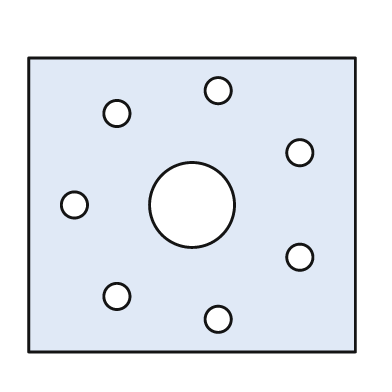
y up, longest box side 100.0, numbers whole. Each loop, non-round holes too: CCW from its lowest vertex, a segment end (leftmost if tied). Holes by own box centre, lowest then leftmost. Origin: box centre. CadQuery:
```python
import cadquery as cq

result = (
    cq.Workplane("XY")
    .moveTo(-50.0, -45.0)
    .lineTo(50.0, -45.0)
    .lineTo(50.0, 45.0)
    .lineTo(-50.0, 45.0)
    .close()
    .moveTo(8.0, -35.0)
    .circle(4.0)
    .moveTo(-23.0, -28.0)
    .circle(4.0)
    .moveTo(33.0, -16.0)
    .circle(4.0)
    .moveTo(-36.0, 0.0)
    .circle(4.0)
    .moveTo(0.0, 0.0)
    .circle(13.0)
    .moveTo(33.0, 16.0)
    .circle(4.0)
    .moveTo(-23.0, 28.0)
    .circle(4.0)
    .moveTo(8.0, 35.0)
    .circle(4.0)
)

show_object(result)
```